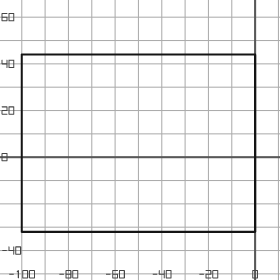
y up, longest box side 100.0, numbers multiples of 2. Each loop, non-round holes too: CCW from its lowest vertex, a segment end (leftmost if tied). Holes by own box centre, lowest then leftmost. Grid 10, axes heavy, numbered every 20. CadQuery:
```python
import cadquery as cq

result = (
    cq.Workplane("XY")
    .moveTo(-100.0, -32.0)
    .lineTo(0.0, -32.0)
    .lineTo(0.0, 44.0)
    .lineTo(-100.0, 44.0)
    .close()
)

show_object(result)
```